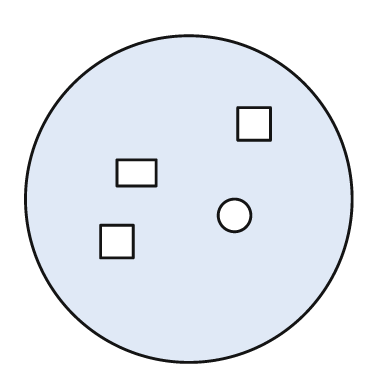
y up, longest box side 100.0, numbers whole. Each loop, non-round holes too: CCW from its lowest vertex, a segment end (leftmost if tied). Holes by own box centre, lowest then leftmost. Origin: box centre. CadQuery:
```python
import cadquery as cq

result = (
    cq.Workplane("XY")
    .moveTo(0.0, 0.0)
    .circle(50.0)
    .moveTo(-27.0, -18.0)
    .lineTo(-17.0, -18.0)
    .lineTo(-17.0, -8.0)
    .lineTo(-27.0, -8.0)
    .close()
    .moveTo(14.0, -5.0)
    .circle(5.0)
    .moveTo(-22.0, 4.0)
    .lineTo(-10.0, 4.0)
    .lineTo(-10.0, 12.0)
    .lineTo(-22.0, 12.0)
    .close()
    .moveTo(15.0, 18.0)
    .lineTo(25.0, 18.0)
    .lineTo(25.0, 28.0)
    .lineTo(15.0, 28.0)
    .close()
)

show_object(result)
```